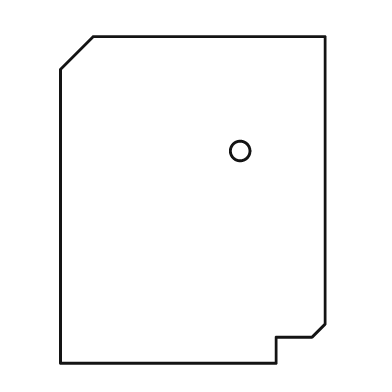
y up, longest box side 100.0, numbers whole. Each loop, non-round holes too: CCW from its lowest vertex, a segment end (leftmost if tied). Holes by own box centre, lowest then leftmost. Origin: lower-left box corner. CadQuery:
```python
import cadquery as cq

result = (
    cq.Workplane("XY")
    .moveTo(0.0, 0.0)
    .lineTo(66.0, 0.0)
    .lineTo(66.0, 8.0)
    .lineTo(77.0, 8.0)
    .lineTo(81.0, 12.0)
    .lineTo(81.0, 100.0)
    .lineTo(10.0, 100.0)
    .lineTo(0.0, 90.0)
    .close()
    .moveTo(55.0, 65.0)
    .circle(3.0)
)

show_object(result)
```